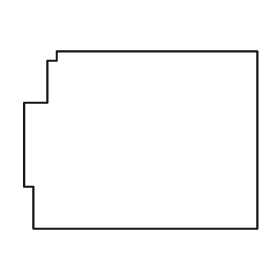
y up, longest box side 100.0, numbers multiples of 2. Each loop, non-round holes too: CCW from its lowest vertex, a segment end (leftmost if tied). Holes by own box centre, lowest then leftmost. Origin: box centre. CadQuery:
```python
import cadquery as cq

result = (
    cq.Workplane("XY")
    .moveTo(-46.0, -38.0)
    .lineTo(50.0, -38.0)
    .lineTo(50.0, 38.0)
    .lineTo(-36.0, 38.0)
    .lineTo(-36.0, 34.0)
    .lineTo(-40.0, 34.0)
    .lineTo(-40.0, 16.0)
    .lineTo(-50.0, 16.0)
    .lineTo(-50.0, -20.0)
    .lineTo(-46.0, -20.0)
    .close()
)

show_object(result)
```